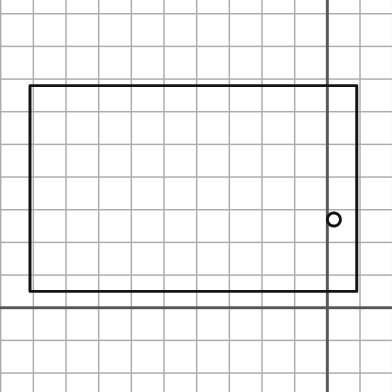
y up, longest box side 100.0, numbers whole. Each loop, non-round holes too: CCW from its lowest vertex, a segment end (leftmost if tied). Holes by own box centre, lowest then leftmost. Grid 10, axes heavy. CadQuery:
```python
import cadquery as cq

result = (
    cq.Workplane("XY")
    .moveTo(-91.0, 5.0)
    .lineTo(9.0, 5.0)
    .lineTo(9.0, 68.0)
    .lineTo(-91.0, 68.0)
    .close()
    .moveTo(2.0, 27.0)
    .circle(2.0)
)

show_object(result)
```